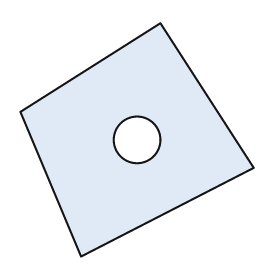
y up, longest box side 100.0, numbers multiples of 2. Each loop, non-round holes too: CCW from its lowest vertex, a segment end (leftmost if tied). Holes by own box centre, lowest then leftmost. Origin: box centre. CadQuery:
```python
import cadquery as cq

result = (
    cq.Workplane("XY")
    .moveTo(-24.0, -50.0)
    .lineTo(50.0, -12.0)
    .lineTo(10.0, 50.0)
    .lineTo(-50.0, 12.0)
    .close()
    .moveTo(0.0, 0.0)
    .circle(10.0)
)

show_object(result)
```